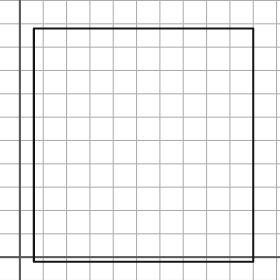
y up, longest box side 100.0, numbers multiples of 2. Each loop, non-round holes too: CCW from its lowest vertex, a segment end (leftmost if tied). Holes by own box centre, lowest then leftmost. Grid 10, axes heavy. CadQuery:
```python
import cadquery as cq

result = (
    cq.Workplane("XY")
    .moveTo(6.0, -2.0)
    .lineTo(100.0, -2.0)
    .lineTo(100.0, 98.0)
    .lineTo(6.0, 98.0)
    .close()
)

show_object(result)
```